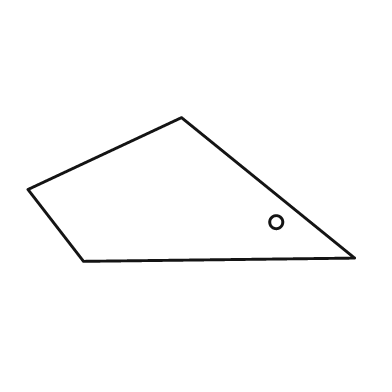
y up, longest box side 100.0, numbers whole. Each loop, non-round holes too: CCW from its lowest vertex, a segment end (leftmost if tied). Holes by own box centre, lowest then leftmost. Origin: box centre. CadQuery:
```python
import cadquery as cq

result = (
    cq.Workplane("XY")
    .moveTo(-33.0, -22.0)
    .lineTo(50.0, -21.0)
    .lineTo(-3.0, 22.0)
    .lineTo(-50.0, 0.0)
    .close()
    .moveTo(26.0, -10.0)
    .circle(2.0)
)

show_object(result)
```